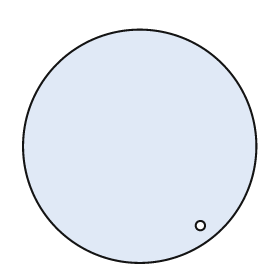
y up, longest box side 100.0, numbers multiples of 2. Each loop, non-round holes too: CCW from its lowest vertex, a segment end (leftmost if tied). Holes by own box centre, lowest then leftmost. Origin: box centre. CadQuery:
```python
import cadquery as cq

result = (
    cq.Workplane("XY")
    .moveTo(0.0, 0.0)
    .circle(50.0)
    .moveTo(26.0, -34.0)
    .circle(2.0)
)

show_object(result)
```